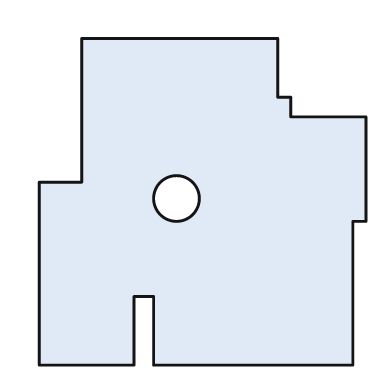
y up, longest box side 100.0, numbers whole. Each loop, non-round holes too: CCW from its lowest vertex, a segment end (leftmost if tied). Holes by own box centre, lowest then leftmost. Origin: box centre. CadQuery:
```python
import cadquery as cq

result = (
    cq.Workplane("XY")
    .moveTo(-50.0, -50.0)
    .lineTo(-21.0, -50.0)
    .lineTo(-21.0, -29.0)
    .lineTo(-15.0, -29.0)
    .lineTo(-15.0, -50.0)
    .lineTo(46.0, -50.0)
    .lineTo(46.0, -6.0)
    .lineTo(50.0, -6.0)
    .lineTo(50.0, 26.0)
    .lineTo(27.0, 26.0)
    .lineTo(27.0, 32.0)
    .lineTo(23.0, 32.0)
    .lineTo(23.0, 50.0)
    .lineTo(-37.0, 50.0)
    .lineTo(-37.0, 6.0)
    .lineTo(-50.0, 6.0)
    .close()
    .moveTo(-8.0, 1.0)
    .circle(7.0)
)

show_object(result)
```